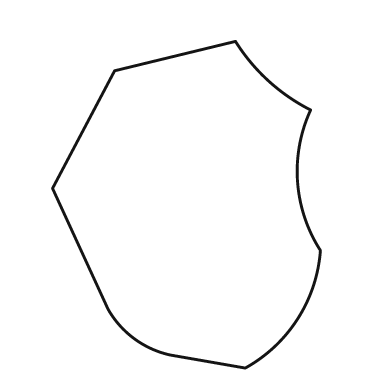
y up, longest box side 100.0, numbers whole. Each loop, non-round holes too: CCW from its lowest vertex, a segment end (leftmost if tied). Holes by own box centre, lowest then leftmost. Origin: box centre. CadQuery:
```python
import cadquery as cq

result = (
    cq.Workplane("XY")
    .moveTo(18.0, -50.0)
    .threePointArc((34.0, -35.0), (41.0, -14.0))
    .threePointArc((34.0, 7.0), (38.0, 29.0))
    .threePointArc((25.0, 38.0), (15.0, 50.0))
    .lineTo(-22.0, 41.0)
    .lineTo(-41.0, 5.0)
    .lineTo(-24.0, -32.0)
    .threePointArc((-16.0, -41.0), (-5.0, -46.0))
    .close()
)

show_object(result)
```